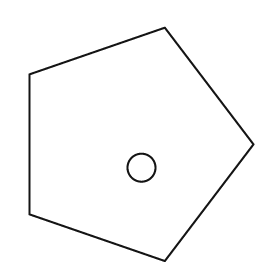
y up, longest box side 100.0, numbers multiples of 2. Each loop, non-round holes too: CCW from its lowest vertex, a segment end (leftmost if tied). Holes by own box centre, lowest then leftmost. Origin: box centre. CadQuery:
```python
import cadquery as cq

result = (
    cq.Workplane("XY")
    .moveTo(10.0, -50.0)
    .lineTo(48.0, 0.0)
    .lineTo(10.0, 50.0)
    .lineTo(-48.0, 30.0)
    .lineTo(-48.0, -30.0)
    .close()
    .moveTo(0.0, -10.0)
    .circle(6.0)
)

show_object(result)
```